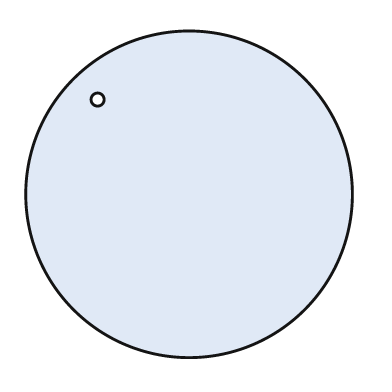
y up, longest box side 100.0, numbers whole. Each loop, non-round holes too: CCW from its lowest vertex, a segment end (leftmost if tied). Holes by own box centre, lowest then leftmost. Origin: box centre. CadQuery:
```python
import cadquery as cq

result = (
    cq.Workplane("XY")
    .moveTo(0.0, 0.0)
    .circle(50.0)
    .moveTo(-28.0, 29.0)
    .circle(2.0)
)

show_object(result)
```